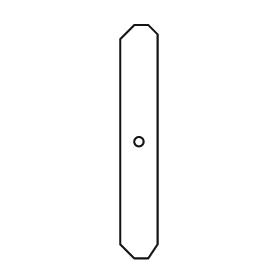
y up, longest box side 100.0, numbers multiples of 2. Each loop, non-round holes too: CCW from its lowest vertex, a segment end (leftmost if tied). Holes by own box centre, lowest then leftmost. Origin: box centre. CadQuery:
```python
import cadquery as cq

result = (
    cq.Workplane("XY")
    .moveTo(-2.0, -50.0)
    .lineTo(4.0, -50.0)
    .lineTo(8.0, -44.0)
    .lineTo(8.0, 46.0)
    .lineTo(4.0, 50.0)
    .lineTo(-2.0, 50.0)
    .lineTo(-8.0, 44.0)
    .lineTo(-8.0, -44.0)
    .close()
    .moveTo(0.0, 0.0)
    .circle(2.0)
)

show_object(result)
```